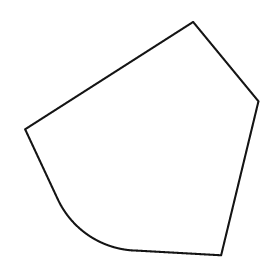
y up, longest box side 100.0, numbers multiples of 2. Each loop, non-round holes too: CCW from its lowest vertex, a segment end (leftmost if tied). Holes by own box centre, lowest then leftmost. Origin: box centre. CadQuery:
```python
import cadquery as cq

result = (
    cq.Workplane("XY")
    .moveTo(34.0, -50.0)
    .lineTo(50.0, 16.0)
    .lineTo(22.0, 50.0)
    .lineTo(-50.0, 4.0)
    .lineTo(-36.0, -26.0)
    .threePointArc((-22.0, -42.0), (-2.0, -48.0))
    .close()
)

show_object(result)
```